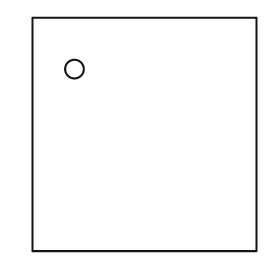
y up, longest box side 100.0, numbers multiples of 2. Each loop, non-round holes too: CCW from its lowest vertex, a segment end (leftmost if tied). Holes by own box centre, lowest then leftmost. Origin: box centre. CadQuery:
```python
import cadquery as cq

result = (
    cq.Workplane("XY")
    .moveTo(-48.0, -50.0)
    .lineTo(48.0, -50.0)
    .lineTo(48.0, 50.0)
    .lineTo(-48.0, 50.0)
    .close()
    .moveTo(-30.0, 28.0)
    .circle(4.0)
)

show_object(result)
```